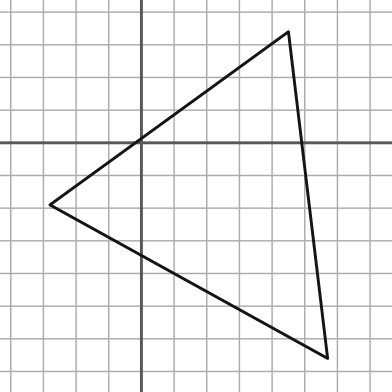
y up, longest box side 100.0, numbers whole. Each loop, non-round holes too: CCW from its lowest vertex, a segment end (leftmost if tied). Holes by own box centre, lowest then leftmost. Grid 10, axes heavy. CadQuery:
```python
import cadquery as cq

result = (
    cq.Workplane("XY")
    .moveTo(57.0, -66.0)
    .lineTo(45.0, 34.0)
    .lineTo(-28.0, -19.0)
    .close()
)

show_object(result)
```